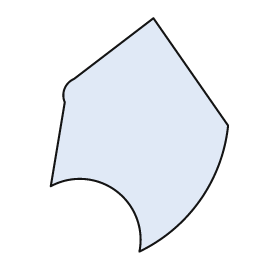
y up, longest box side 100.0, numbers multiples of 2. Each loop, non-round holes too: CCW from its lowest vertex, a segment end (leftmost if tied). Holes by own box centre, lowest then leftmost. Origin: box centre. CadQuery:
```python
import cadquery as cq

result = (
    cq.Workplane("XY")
    .moveTo(0.0, -50.0)
    .threePointArc((26.0, -28.0), (38.0, 4.0))
    .lineTo(6.0, 50.0)
    .lineTo(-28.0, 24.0)
    .threePointArc((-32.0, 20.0), (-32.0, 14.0))
    .lineTo(-38.0, -22.0)
    .threePointArc((-10.0, -24.0), (0.0, -50.0))
    .close()
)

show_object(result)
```